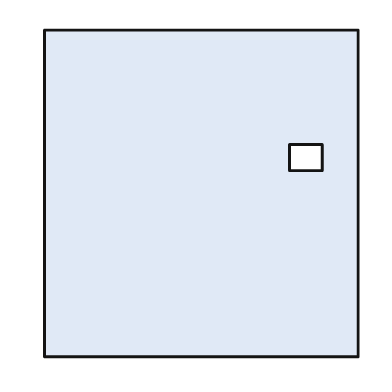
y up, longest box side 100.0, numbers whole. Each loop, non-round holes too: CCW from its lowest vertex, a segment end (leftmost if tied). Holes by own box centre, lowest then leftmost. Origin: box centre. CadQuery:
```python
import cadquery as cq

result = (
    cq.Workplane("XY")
    .moveTo(-48.0, -50.0)
    .lineTo(48.0, -50.0)
    .lineTo(48.0, 50.0)
    .lineTo(-48.0, 50.0)
    .close()
    .moveTo(27.0, 7.0)
    .lineTo(37.0, 7.0)
    .lineTo(37.0, 15.0)
    .lineTo(27.0, 15.0)
    .close()
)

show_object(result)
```